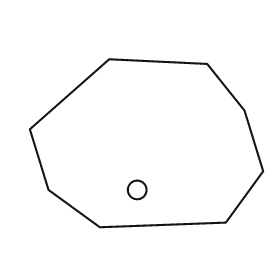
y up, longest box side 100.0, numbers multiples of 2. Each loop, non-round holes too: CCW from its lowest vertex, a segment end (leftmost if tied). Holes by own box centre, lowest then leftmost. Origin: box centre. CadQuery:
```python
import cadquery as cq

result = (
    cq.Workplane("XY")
    .moveTo(-20.0, -36.0)
    .lineTo(34.0, -34.0)
    .lineTo(50.0, -12.0)
    .lineTo(42.0, 14.0)
    .lineTo(26.0, 34.0)
    .lineTo(-16.0, 36.0)
    .lineTo(-50.0, 6.0)
    .lineTo(-42.0, -20.0)
    .close()
    .moveTo(-4.0, -20.0)
    .circle(4.0)
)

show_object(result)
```